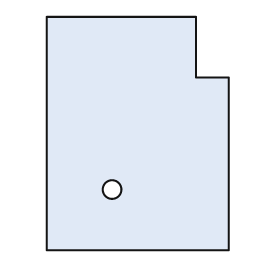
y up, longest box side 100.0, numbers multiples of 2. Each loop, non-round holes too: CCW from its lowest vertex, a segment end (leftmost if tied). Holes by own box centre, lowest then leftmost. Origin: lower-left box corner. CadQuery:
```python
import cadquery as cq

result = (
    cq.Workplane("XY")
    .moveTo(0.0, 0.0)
    .lineTo(78.0, 0.0)
    .lineTo(78.0, 74.0)
    .lineTo(64.0, 74.0)
    .lineTo(64.0, 100.0)
    .lineTo(0.0, 100.0)
    .close()
    .moveTo(28.0, 26.0)
    .circle(4.0)
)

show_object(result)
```